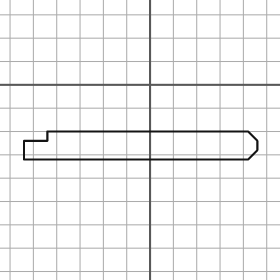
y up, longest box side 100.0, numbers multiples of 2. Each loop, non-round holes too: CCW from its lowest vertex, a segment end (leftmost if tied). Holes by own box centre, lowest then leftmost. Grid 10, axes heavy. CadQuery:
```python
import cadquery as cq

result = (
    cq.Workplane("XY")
    .moveTo(-54.0, -32.0)
    .lineTo(42.0, -32.0)
    .lineTo(46.0, -28.0)
    .lineTo(46.0, -24.0)
    .lineTo(42.0, -20.0)
    .lineTo(-44.0, -20.0)
    .lineTo(-44.0, -24.0)
    .lineTo(-54.0, -24.0)
    .close()
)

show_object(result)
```